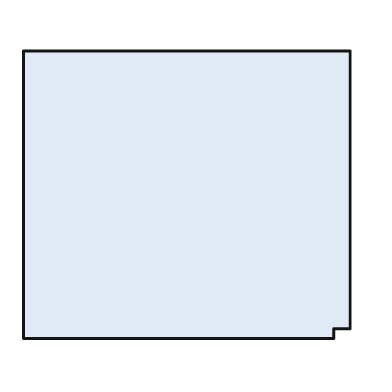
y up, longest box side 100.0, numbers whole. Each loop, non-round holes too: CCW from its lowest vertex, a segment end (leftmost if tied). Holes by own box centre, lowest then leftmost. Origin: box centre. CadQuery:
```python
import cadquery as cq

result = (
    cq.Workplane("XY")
    .moveTo(-50.0, -44.0)
    .lineTo(45.0, -44.0)
    .lineTo(45.0, -41.0)
    .lineTo(50.0, -41.0)
    .lineTo(50.0, 44.0)
    .lineTo(-50.0, 44.0)
    .close()
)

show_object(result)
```